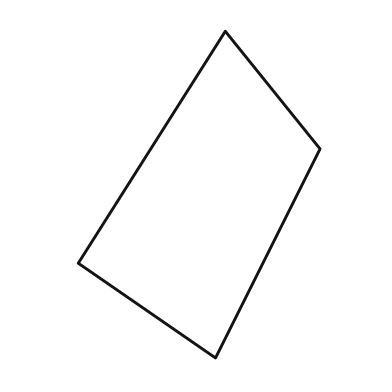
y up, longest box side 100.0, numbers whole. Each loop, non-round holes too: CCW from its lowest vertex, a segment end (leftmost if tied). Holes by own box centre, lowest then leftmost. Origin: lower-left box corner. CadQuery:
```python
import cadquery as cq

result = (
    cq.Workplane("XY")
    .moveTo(42.0, 0.0)
    .lineTo(74.0, 64.0)
    .lineTo(45.0, 100.0)
    .lineTo(0.0, 29.0)
    .close()
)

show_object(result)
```